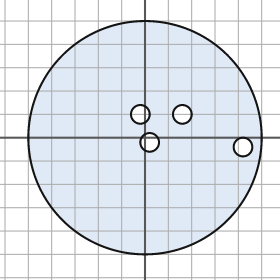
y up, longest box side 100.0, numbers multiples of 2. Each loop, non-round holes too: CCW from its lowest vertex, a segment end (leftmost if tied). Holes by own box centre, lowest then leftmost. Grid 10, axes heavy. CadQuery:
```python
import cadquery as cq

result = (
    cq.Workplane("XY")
    .moveTo(0.0, 0.0)
    .circle(50.0)
    .moveTo(42.0, -4.0)
    .circle(4.0)
    .moveTo(2.0, -2.0)
    .circle(4.0)
    .moveTo(-2.0, 10.0)
    .circle(4.0)
    .moveTo(16.0, 10.0)
    .circle(4.0)
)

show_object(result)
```